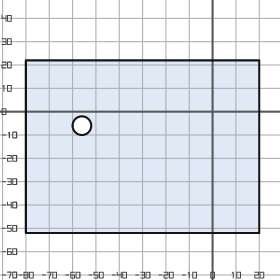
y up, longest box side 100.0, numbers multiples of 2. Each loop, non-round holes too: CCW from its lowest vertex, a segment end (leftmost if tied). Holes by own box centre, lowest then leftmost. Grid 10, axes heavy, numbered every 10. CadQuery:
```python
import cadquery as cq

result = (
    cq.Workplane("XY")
    .moveTo(-80.0, -52.0)
    .lineTo(20.0, -52.0)
    .lineTo(20.0, 22.0)
    .lineTo(-80.0, 22.0)
    .close()
    .moveTo(-56.0, -6.0)
    .circle(4.0)
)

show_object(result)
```